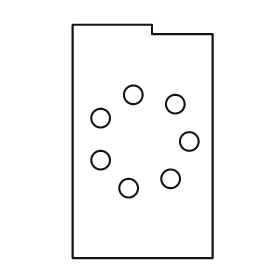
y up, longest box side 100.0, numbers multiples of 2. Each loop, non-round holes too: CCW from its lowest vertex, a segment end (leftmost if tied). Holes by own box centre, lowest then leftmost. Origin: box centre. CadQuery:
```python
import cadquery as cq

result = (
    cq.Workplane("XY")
    .moveTo(-30.0, -50.0)
    .lineTo(30.0, -50.0)
    .lineTo(30.0, 46.0)
    .lineTo(4.0, 46.0)
    .lineTo(4.0, 50.0)
    .lineTo(-30.0, 50.0)
    .close()
    .moveTo(-6.0, -20.0)
    .circle(4.0)
    .moveTo(12.0, -16.0)
    .circle(4.0)
    .moveTo(-18.0, -8.0)
    .circle(4.0)
    .moveTo(20.0, 0.0)
    .circle(4.0)
    .moveTo(-18.0, 10.0)
    .circle(4.0)
    .moveTo(14.0, 16.0)
    .circle(4.0)
    .moveTo(-4.0, 20.0)
    .circle(4.0)
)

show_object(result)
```